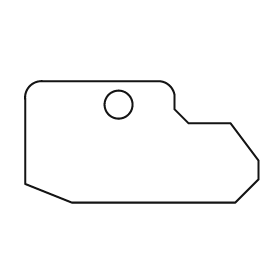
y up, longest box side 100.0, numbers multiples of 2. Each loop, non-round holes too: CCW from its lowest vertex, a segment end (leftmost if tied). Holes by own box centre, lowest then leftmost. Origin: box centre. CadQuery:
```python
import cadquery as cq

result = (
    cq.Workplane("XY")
    .moveTo(-30.0, -26.0)
    .lineTo(40.0, -26.0)
    .lineTo(50.0, -16.0)
    .lineTo(50.0, -8.0)
    .lineTo(38.0, 8.0)
    .lineTo(20.0, 8.0)
    .lineTo(14.0, 14.0)
    .lineTo(14.0, 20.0)
    .threePointArc((12.0, 24.0), (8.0, 26.0))
    .lineTo(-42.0, 26.0)
    .threePointArc((-48.0, 24.0), (-50.0, 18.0))
    .lineTo(-50.0, -18.0)
    .close()
    .moveTo(-10.0, 16.0)
    .circle(6.0)
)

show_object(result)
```